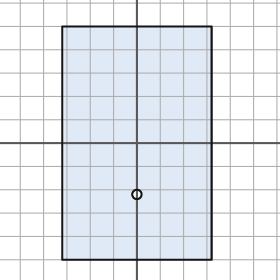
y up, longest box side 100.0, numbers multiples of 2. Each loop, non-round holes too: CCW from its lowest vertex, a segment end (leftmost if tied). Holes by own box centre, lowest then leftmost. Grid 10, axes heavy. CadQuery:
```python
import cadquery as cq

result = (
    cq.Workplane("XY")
    .moveTo(-32.0, -50.0)
    .lineTo(32.0, -50.0)
    .lineTo(32.0, 50.0)
    .lineTo(-32.0, 50.0)
    .close()
    .moveTo(0.0, -22.0)
    .circle(2.0)
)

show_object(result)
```